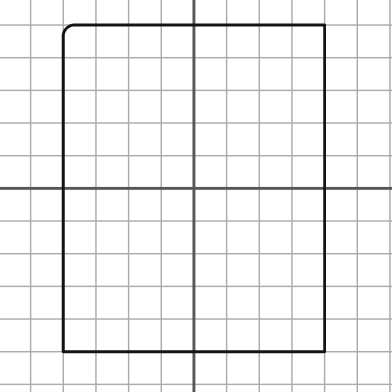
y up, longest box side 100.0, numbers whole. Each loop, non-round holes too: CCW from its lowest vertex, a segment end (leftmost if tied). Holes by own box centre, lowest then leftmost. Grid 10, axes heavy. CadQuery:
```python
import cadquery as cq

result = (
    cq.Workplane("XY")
    .moveTo(-40.0, -50.0)
    .lineTo(40.0, -50.0)
    .lineTo(40.0, 50.0)
    .lineTo(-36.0, 50.0)
    .threePointArc((-39.0, 49.0), (-40.0, 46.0))
    .close()
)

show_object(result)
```